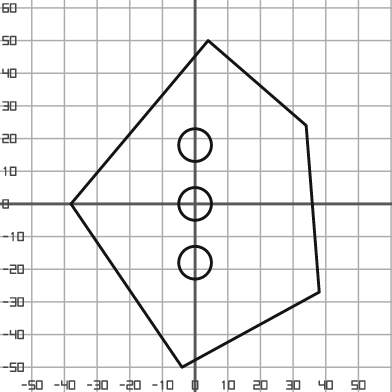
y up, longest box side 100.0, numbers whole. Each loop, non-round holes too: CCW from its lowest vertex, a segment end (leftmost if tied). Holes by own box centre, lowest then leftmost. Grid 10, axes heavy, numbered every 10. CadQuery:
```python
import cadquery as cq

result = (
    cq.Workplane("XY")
    .moveTo(-4.0, -50.0)
    .lineTo(38.0, -27.0)
    .lineTo(34.0, 24.0)
    .lineTo(4.0, 50.0)
    .lineTo(-38.0, 0.0)
    .close()
    .moveTo(0.0, -18.0)
    .circle(5.0)
    .moveTo(0.0, 0.0)
    .circle(5.0)
    .moveTo(0.0, 18.0)
    .circle(5.0)
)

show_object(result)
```